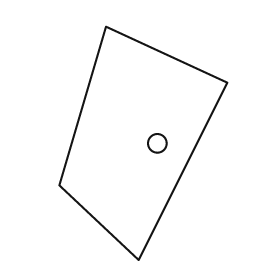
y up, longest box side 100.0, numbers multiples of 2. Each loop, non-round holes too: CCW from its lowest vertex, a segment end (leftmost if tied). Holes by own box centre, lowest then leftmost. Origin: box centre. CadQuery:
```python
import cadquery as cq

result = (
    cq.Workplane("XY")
    .moveTo(-2.0, -50.0)
    .lineTo(36.0, 26.0)
    .lineTo(-16.0, 50.0)
    .lineTo(-36.0, -18.0)
    .close()
    .moveTo(6.0, 0.0)
    .circle(4.0)
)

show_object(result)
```